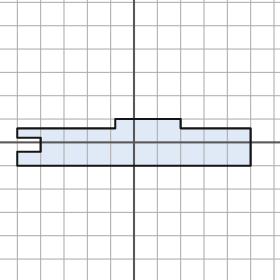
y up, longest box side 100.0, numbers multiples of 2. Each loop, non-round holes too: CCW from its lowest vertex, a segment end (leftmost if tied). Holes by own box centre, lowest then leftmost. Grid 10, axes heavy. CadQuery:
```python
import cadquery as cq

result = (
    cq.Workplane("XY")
    .moveTo(-50.0, -10.0)
    .lineTo(50.0, -10.0)
    .lineTo(50.0, 6.0)
    .lineTo(20.0, 6.0)
    .lineTo(20.0, 10.0)
    .lineTo(-8.0, 10.0)
    .lineTo(-8.0, 6.0)
    .lineTo(-50.0, 6.0)
    .lineTo(-50.0, 2.0)
    .lineTo(-40.0, 2.0)
    .lineTo(-40.0, -4.0)
    .lineTo(-50.0, -4.0)
    .close()
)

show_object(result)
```